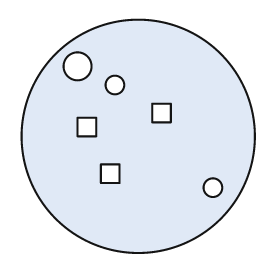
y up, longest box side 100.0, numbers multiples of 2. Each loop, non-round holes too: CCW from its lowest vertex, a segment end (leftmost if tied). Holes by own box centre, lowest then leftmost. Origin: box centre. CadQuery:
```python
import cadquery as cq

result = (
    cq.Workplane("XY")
    .moveTo(0.0, 0.0)
    .circle(50.0)
    .moveTo(32.0, -22.0)
    .circle(4.0)
    .moveTo(-16.0, -20.0)
    .lineTo(-8.0, -20.0)
    .lineTo(-8.0, -12.0)
    .lineTo(-16.0, -12.0)
    .close()
    .moveTo(-26.0, 0.0)
    .lineTo(-18.0, 0.0)
    .lineTo(-18.0, 8.0)
    .lineTo(-26.0, 8.0)
    .close()
    .moveTo(6.0, 6.0)
    .lineTo(14.0, 6.0)
    .lineTo(14.0, 14.0)
    .lineTo(6.0, 14.0)
    .close()
    .moveTo(-10.0, 22.0)
    .circle(4.0)
    .moveTo(-26.0, 30.0)
    .circle(6.0)
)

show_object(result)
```